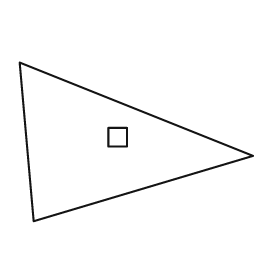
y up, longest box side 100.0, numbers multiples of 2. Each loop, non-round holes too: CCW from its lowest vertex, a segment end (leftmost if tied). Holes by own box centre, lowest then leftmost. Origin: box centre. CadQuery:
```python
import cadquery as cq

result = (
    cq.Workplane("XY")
    .moveTo(-44.0, -34.0)
    .lineTo(50.0, -6.0)
    .lineTo(-50.0, 34.0)
    .close()
    .moveTo(-12.0, -2.0)
    .lineTo(-4.0, -2.0)
    .lineTo(-4.0, 6.0)
    .lineTo(-12.0, 6.0)
    .close()
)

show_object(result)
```